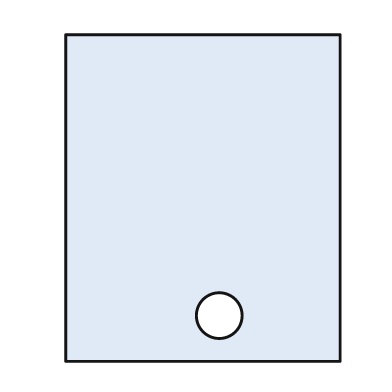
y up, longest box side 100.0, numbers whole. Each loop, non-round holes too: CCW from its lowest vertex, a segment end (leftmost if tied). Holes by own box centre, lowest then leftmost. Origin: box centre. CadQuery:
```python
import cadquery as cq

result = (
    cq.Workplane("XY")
    .moveTo(-42.0, -50.0)
    .lineTo(42.0, -50.0)
    .lineTo(42.0, 50.0)
    .lineTo(-42.0, 50.0)
    .close()
    .moveTo(5.0, -36.0)
    .circle(7.0)
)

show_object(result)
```